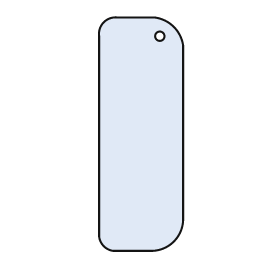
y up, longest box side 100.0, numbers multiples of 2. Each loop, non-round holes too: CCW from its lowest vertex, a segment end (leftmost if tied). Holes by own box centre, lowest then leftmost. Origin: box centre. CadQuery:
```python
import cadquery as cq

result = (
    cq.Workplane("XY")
    .moveTo(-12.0, -50.0)
    .lineTo(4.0, -50.0)
    .threePointArc((14.0, -46.0), (18.0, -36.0))
    .lineTo(18.0, 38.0)
    .threePointArc((14.0, 46.0), (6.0, 50.0))
    .lineTo(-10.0, 50.0)
    .threePointArc((-16.0, 48.0), (-18.0, 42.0))
    .lineTo(-18.0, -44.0)
    .threePointArc((-16.0, -48.0), (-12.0, -50.0))
    .close()
    .moveTo(8.0, 42.0)
    .circle(2.0)
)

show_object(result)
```